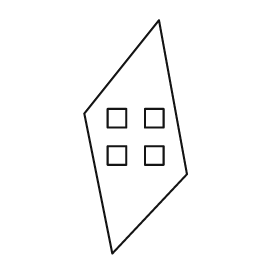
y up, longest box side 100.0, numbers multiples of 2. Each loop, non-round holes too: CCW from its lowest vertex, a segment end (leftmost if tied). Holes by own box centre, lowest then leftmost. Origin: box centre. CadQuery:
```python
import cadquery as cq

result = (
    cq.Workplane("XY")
    .moveTo(-10.0, -50.0)
    .lineTo(22.0, -16.0)
    .lineTo(10.0, 50.0)
    .lineTo(-22.0, 10.0)
    .close()
    .moveTo(-12.0, -12.0)
    .lineTo(-4.0, -12.0)
    .lineTo(-4.0, -4.0)
    .lineTo(-12.0, -4.0)
    .close()
    .moveTo(4.0, -12.0)
    .lineTo(12.0, -12.0)
    .lineTo(12.0, -4.0)
    .lineTo(4.0, -4.0)
    .close()
    .moveTo(-12.0, 4.0)
    .lineTo(-4.0, 4.0)
    .lineTo(-4.0, 12.0)
    .lineTo(-12.0, 12.0)
    .close()
    .moveTo(4.0, 4.0)
    .lineTo(12.0, 4.0)
    .lineTo(12.0, 12.0)
    .lineTo(4.0, 12.0)
    .close()
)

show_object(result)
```